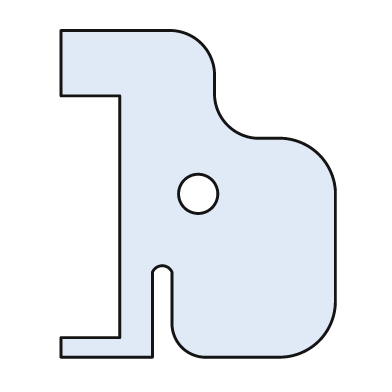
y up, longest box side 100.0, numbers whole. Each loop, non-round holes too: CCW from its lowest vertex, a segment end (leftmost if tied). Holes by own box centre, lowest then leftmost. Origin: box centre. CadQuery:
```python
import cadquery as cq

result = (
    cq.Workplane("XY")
    .moveTo(-42.0, -50.0)
    .lineTo(-14.0, -50.0)
    .lineTo(-14.0, -24.0)
    .threePointArc((-11.0, -22.0), (-8.0, -24.0))
    .lineTo(-8.0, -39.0)
    .threePointArc((-5.0, -47.0), (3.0, -50.0))
    .lineTo(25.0, -50.0)
    .threePointArc((37.0, -45.0), (42.0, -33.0))
    .lineTo(42.0, 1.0)
    .threePointArc((37.0, 12.0), (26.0, 17.0))
    .lineTo(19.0, 17.0)
    .threePointArc((9.0, 21.0), (5.0, 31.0))
    .lineTo(5.0, 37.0)
    .threePointArc((1.0, 46.0), (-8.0, 50.0))
    .lineTo(-42.0, 50.0)
    .lineTo(-42.0, 30.0)
    .lineTo(-24.0, 30.0)
    .lineTo(-24.0, -44.0)
    .lineTo(-42.0, -44.0)
    .close()
    .moveTo(0.0, 0.0)
    .circle(6.0)
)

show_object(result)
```